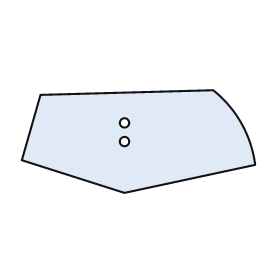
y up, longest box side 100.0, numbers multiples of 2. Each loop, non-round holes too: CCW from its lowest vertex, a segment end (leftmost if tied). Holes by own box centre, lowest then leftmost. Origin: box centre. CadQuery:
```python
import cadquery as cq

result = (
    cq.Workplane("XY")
    .moveTo(-6.0, -22.0)
    .lineTo(50.0, -10.0)
    .threePointArc((44.0, 8.0), (32.0, 22.0))
    .lineTo(-42.0, 20.0)
    .lineTo(-50.0, -8.0)
    .close()
    .moveTo(-6.0, 0.0)
    .circle(2.0)
    .moveTo(-6.0, 8.0)
    .circle(2.0)
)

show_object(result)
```